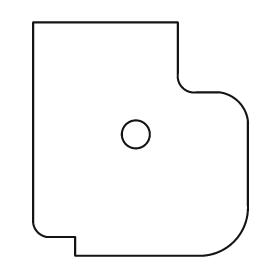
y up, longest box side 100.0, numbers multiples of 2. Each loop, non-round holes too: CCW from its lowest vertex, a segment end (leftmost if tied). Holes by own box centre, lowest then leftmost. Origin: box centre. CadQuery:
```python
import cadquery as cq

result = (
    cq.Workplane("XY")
    .moveTo(-28.0, -50.0)
    .lineTo(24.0, -50.0)
    .threePointArc((40.0, -44.0), (46.0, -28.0))
    .lineTo(46.0, 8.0)
    .threePointArc((42.0, 16.0), (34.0, 20.0))
    .lineTo(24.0, 20.0)
    .threePointArc((18.0, 22.0), (16.0, 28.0))
    .lineTo(16.0, 50.0)
    .lineTo(-46.0, 50.0)
    .lineTo(-46.0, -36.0)
    .threePointArc((-44.0, -40.0), (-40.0, -42.0))
    .lineTo(-28.0, -42.0)
    .close()
    .moveTo(-2.0, 2.0)
    .circle(6.0)
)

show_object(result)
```